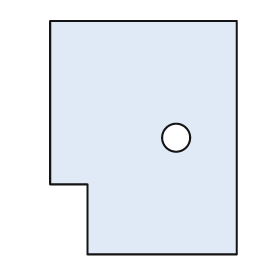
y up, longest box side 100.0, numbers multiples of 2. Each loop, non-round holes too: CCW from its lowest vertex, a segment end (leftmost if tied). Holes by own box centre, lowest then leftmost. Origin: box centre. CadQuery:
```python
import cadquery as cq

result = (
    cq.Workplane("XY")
    .moveTo(-24.0, -50.0)
    .lineTo(40.0, -50.0)
    .lineTo(40.0, 50.0)
    .lineTo(-40.0, 50.0)
    .lineTo(-40.0, -20.0)
    .lineTo(-24.0, -20.0)
    .close()
    .moveTo(14.0, 0.0)
    .circle(6.0)
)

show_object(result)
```